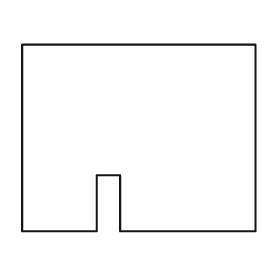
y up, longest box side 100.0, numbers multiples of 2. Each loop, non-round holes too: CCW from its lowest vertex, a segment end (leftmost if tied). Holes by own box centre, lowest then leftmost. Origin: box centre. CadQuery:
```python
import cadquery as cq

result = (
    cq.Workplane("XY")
    .moveTo(-50.0, -40.0)
    .lineTo(-18.0, -40.0)
    .lineTo(-18.0, -16.0)
    .lineTo(-8.0, -16.0)
    .lineTo(-8.0, -40.0)
    .lineTo(50.0, -40.0)
    .lineTo(50.0, 40.0)
    .lineTo(-50.0, 40.0)
    .close()
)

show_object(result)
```